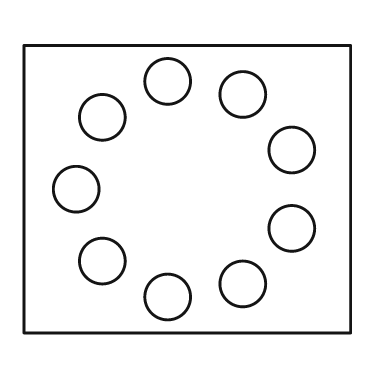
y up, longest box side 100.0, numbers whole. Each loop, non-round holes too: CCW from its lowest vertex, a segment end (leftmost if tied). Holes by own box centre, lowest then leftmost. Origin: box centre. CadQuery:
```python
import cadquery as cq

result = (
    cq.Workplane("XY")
    .moveTo(-50.0, -44.0)
    .lineTo(50.0, -44.0)
    .lineTo(50.0, 44.0)
    .lineTo(-50.0, 44.0)
    .close()
    .moveTo(-6.0, -33.0)
    .circle(7.0)
    .moveTo(17.0, -29.0)
    .circle(7.0)
    .moveTo(-26.0, -22.0)
    .circle(7.0)
    .moveTo(32.0, -12.0)
    .circle(7.0)
    .moveTo(-34.0, 0.0)
    .circle(7.0)
    .moveTo(32.0, 12.0)
    .circle(7.0)
    .moveTo(-26.0, 22.0)
    .circle(7.0)
    .moveTo(17.0, 29.0)
    .circle(7.0)
    .moveTo(-6.0, 33.0)
    .circle(7.0)
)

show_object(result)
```